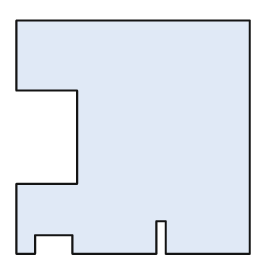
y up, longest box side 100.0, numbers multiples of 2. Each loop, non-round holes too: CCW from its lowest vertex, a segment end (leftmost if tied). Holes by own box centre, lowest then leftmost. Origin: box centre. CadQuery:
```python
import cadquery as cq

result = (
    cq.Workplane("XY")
    .moveTo(-50.0, -50.0)
    .lineTo(-42.0, -50.0)
    .lineTo(-42.0, -42.0)
    .lineTo(-26.0, -42.0)
    .lineTo(-26.0, -50.0)
    .lineTo(10.0, -50.0)
    .lineTo(10.0, -36.0)
    .lineTo(14.0, -36.0)
    .lineTo(14.0, -50.0)
    .lineTo(50.0, -50.0)
    .lineTo(50.0, 50.0)
    .lineTo(-50.0, 50.0)
    .lineTo(-50.0, 20.0)
    .lineTo(-24.0, 20.0)
    .lineTo(-24.0, -20.0)
    .lineTo(-50.0, -20.0)
    .close()
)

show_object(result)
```